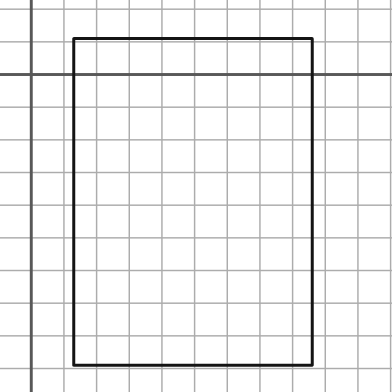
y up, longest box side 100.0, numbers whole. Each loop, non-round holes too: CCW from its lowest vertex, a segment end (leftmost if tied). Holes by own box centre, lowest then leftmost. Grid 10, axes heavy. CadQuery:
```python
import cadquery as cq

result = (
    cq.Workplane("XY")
    .moveTo(13.0, -89.0)
    .lineTo(86.0, -89.0)
    .lineTo(86.0, 11.0)
    .lineTo(13.0, 11.0)
    .close()
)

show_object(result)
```